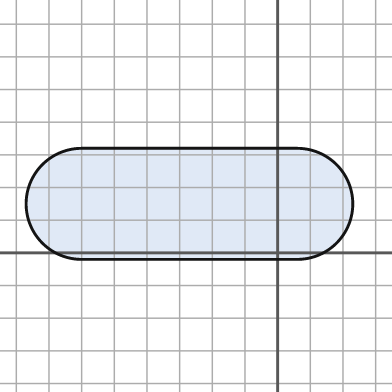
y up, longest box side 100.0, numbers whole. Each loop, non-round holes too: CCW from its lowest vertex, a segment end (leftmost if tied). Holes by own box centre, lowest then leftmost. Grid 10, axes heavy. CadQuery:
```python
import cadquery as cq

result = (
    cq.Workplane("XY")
    .moveTo(-60.0, -2.0)
    .lineTo(6.0, -2.0)
    .threePointArc((23.0, 15.0), (6.0, 32.0))
    .lineTo(-60.0, 32.0)
    .threePointArc((-77.0, 15.0), (-60.0, -2.0))
    .close()
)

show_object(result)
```